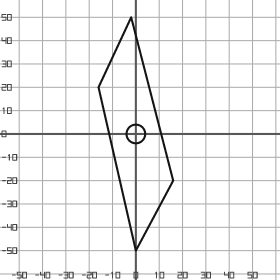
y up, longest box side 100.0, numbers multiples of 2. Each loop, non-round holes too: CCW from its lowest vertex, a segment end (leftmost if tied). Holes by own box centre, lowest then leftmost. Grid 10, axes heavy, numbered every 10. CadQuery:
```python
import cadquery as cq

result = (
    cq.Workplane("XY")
    .moveTo(0.0, -50.0)
    .lineTo(16.0, -20.0)
    .lineTo(-2.0, 50.0)
    .lineTo(-16.0, 20.0)
    .close()
    .moveTo(0.0, 0.0)
    .circle(4.0)
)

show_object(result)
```